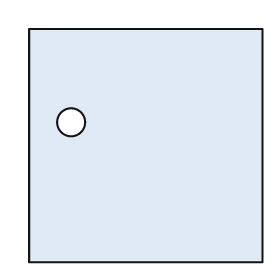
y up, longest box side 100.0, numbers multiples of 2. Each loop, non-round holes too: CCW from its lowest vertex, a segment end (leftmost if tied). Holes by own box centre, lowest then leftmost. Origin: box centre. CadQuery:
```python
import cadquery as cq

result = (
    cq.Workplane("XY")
    .moveTo(-50.0, -50.0)
    .lineTo(50.0, -50.0)
    .lineTo(50.0, 50.0)
    .lineTo(-50.0, 50.0)
    .close()
    .moveTo(-32.0, 10.0)
    .circle(6.0)
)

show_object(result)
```